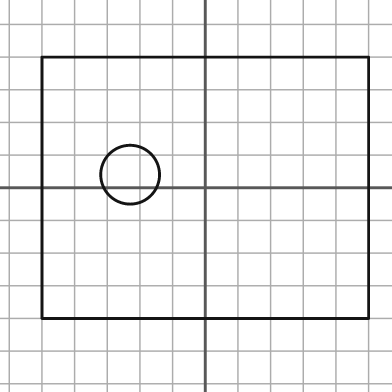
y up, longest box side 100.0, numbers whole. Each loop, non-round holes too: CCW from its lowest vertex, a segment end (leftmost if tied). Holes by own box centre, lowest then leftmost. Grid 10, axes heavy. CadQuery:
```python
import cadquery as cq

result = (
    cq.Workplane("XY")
    .moveTo(-50.0, -40.0)
    .lineTo(50.0, -40.0)
    .lineTo(50.0, 40.0)
    .lineTo(-50.0, 40.0)
    .close()
    .moveTo(-23.0, 4.0)
    .circle(9.0)
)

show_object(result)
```